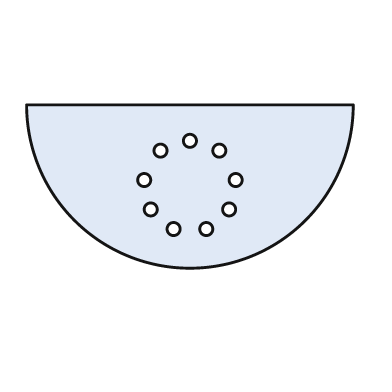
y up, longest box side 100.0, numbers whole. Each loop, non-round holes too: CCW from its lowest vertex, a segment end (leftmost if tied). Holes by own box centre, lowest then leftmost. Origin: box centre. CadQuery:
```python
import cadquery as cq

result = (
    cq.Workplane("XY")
    .moveTo(-50.0, 25.0)
    .threePointArc((0.0, -25.0), (50.0, 25.0))
    .close()
    .moveTo(-5.0, -13.0)
    .circle(2.0)
    .moveTo(5.0, -13.0)
    .circle(2.0)
    .moveTo(-12.0, -7.0)
    .circle(2.0)
    .moveTo(12.0, -7.0)
    .circle(2.0)
    .moveTo(-14.0, 2.0)
    .circle(2.0)
    .moveTo(14.0, 2.0)
    .circle(2.0)
    .moveTo(-9.0, 11.0)
    .circle(2.0)
    .moveTo(9.0, 11.0)
    .circle(2.0)
    .moveTo(0.0, 14.0)
    .circle(2.0)
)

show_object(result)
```